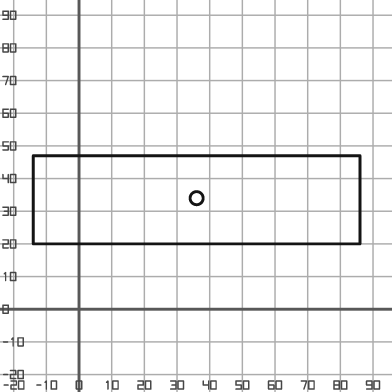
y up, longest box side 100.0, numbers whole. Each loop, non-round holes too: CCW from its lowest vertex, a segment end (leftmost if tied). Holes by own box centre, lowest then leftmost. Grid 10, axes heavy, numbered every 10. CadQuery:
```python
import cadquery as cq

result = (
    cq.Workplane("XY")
    .moveTo(-14.0, 20.0)
    .lineTo(86.0, 20.0)
    .lineTo(86.0, 47.0)
    .lineTo(-14.0, 47.0)
    .close()
    .moveTo(36.0, 34.0)
    .circle(2.0)
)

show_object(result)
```